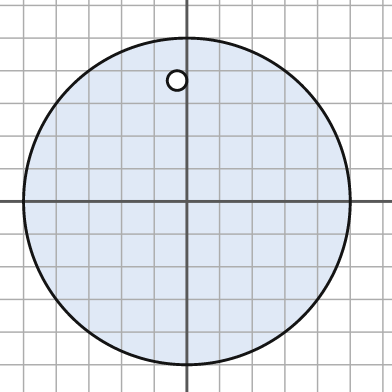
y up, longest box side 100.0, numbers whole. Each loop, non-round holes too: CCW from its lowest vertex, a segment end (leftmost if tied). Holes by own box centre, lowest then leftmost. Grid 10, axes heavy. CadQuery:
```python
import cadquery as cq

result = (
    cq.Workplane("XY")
    .moveTo(0.0, 0.0)
    .circle(50.0)
    .moveTo(-3.0, 37.0)
    .circle(3.0)
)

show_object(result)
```